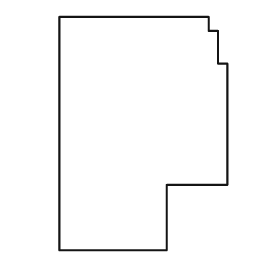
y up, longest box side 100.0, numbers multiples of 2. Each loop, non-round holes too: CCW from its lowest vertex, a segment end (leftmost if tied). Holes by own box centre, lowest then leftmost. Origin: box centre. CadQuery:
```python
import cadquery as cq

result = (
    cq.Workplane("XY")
    .moveTo(-36.0, -50.0)
    .lineTo(10.0, -50.0)
    .lineTo(10.0, -22.0)
    .lineTo(36.0, -22.0)
    .lineTo(36.0, 30.0)
    .lineTo(32.0, 30.0)
    .lineTo(32.0, 44.0)
    .lineTo(28.0, 44.0)
    .lineTo(28.0, 50.0)
    .lineTo(-36.0, 50.0)
    .close()
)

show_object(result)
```